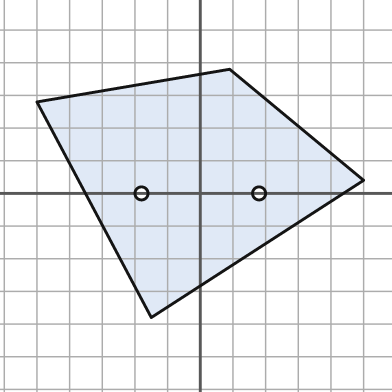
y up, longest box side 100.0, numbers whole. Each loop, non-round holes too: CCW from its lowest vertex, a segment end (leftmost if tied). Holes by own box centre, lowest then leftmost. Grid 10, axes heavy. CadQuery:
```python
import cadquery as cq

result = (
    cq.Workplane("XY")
    .moveTo(-15.0, -38.0)
    .lineTo(50.0, 4.0)
    .lineTo(9.0, 38.0)
    .lineTo(-50.0, 28.0)
    .close()
    .moveTo(-18.0, 0.0)
    .circle(2.0)
    .moveTo(18.0, 0.0)
    .circle(2.0)
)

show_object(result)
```